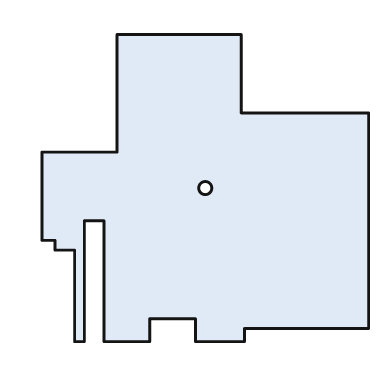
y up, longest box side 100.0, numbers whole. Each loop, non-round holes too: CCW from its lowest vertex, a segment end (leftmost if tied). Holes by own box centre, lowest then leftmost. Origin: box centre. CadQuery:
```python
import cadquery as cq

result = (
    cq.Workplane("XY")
    .moveTo(-40.0, -47.0)
    .lineTo(-37.0, -47.0)
    .lineTo(-37.0, -10.0)
    .lineTo(-31.0, -10.0)
    .lineTo(-31.0, -47.0)
    .lineTo(-17.0, -47.0)
    .lineTo(-17.0, -40.0)
    .lineTo(-3.0, -40.0)
    .lineTo(-3.0, -47.0)
    .lineTo(12.0, -47.0)
    .lineTo(12.0, -43.0)
    .lineTo(50.0, -43.0)
    .lineTo(50.0, 23.0)
    .lineTo(11.0, 23.0)
    .lineTo(11.0, 47.0)
    .lineTo(-27.0, 47.0)
    .lineTo(-27.0, 11.0)
    .lineTo(-50.0, 11.0)
    .lineTo(-50.0, -16.0)
    .lineTo(-46.0, -16.0)
    .lineTo(-46.0, -19.0)
    .lineTo(-40.0, -19.0)
    .close()
    .moveTo(0.0, 0.0)
    .circle(2.0)
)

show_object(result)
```